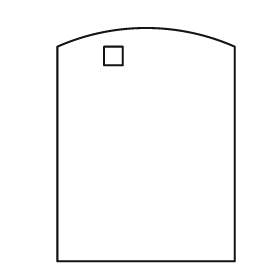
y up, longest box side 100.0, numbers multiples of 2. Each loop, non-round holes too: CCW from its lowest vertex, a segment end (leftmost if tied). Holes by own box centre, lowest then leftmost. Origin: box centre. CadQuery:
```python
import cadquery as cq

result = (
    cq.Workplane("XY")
    .moveTo(-38.0, -50.0)
    .lineTo(38.0, -50.0)
    .lineTo(38.0, 42.0)
    .threePointArc((0.0, 50.0), (-38.0, 42.0))
    .close()
    .moveTo(-18.0, 34.0)
    .lineTo(-10.0, 34.0)
    .lineTo(-10.0, 42.0)
    .lineTo(-18.0, 42.0)
    .close()
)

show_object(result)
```